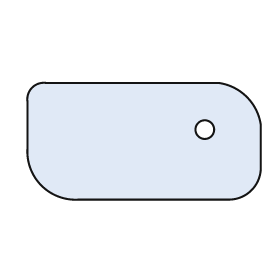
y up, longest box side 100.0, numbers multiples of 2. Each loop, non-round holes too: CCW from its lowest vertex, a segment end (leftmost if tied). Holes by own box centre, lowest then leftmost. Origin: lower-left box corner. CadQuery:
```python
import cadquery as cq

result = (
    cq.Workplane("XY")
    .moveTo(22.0, 0.0)
    .lineTo(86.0, 0.0)
    .threePointArc((96.0, 4.0), (100.0, 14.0))
    .lineTo(100.0, 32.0)
    .threePointArc((94.0, 44.0), (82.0, 50.0))
    .lineTo(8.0, 50.0)
    .threePointArc((2.0, 48.0), (0.0, 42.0))
    .lineTo(0.0, 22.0)
    .threePointArc((6.0, 6.0), (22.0, 0.0))
    .close()
    .moveTo(76.0, 30.0)
    .circle(4.0)
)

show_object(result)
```